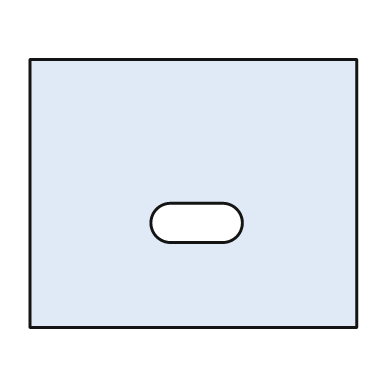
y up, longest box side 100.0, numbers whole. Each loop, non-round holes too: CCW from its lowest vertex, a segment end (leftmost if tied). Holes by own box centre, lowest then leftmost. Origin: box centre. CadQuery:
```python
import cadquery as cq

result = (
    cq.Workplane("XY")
    .moveTo(-50.0, -41.0)
    .lineTo(50.0, -41.0)
    .lineTo(50.0, 41.0)
    .lineTo(-50.0, 41.0)
    .close()
    .moveTo(-7.0, -15.0)
    .lineTo(9.0, -15.0)
    .threePointArc((15.0, -9.0), (9.0, -3.0))
    .lineTo(-7.0, -3.0)
    .threePointArc((-13.0, -9.0), (-7.0, -15.0))
    .close()
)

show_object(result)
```